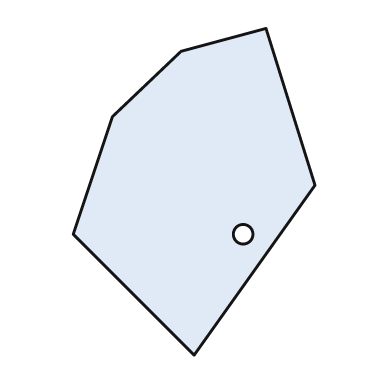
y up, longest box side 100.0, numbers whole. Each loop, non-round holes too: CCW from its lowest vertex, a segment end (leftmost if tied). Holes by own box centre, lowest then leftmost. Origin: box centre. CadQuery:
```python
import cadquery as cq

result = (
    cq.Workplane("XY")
    .moveTo(0.0, -50.0)
    .lineTo(37.0, 2.0)
    .lineTo(22.0, 50.0)
    .lineTo(-4.0, 43.0)
    .lineTo(-25.0, 23.0)
    .lineTo(-37.0, -13.0)
    .close()
    .moveTo(15.0, -13.0)
    .circle(3.0)
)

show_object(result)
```